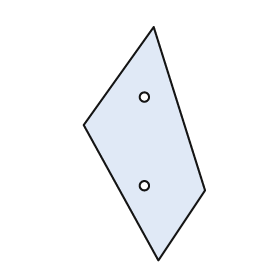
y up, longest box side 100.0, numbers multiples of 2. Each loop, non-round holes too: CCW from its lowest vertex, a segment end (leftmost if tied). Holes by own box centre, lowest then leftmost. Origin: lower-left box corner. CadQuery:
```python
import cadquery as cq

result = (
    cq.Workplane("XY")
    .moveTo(32.0, 0.0)
    .lineTo(52.0, 30.0)
    .lineTo(30.0, 100.0)
    .lineTo(0.0, 58.0)
    .close()
    .moveTo(26.0, 32.0)
    .circle(2.0)
    .moveTo(26.0, 70.0)
    .circle(2.0)
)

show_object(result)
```